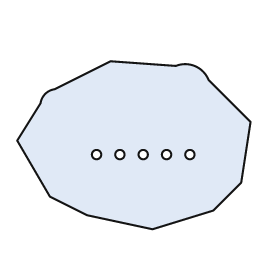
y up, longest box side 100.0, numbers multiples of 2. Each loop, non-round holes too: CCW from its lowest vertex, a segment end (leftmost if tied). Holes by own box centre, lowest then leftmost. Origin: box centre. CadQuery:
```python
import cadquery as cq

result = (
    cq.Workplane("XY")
    .moveTo(8.0, -36.0)
    .lineTo(34.0, -28.0)
    .lineTo(46.0, -16.0)
    .lineTo(50.0, 10.0)
    .lineTo(32.0, 28.0)
    .threePointArc((26.0, 34.0), (18.0, 34.0))
    .lineTo(-10.0, 36.0)
    .lineTo(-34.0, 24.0)
    .threePointArc((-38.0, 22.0), (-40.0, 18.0))
    .lineTo(-50.0, 2.0)
    .lineTo(-36.0, -22.0)
    .lineTo(-20.0, -30.0)
    .close()
    .moveTo(-16.0, -4.0)
    .circle(2.0)
    .moveTo(-6.0, -4.0)
    .circle(2.0)
    .moveTo(4.0, -4.0)
    .circle(2.0)
    .moveTo(14.0, -4.0)
    .circle(2.0)
    .moveTo(24.0, -4.0)
    .circle(2.0)
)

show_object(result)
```